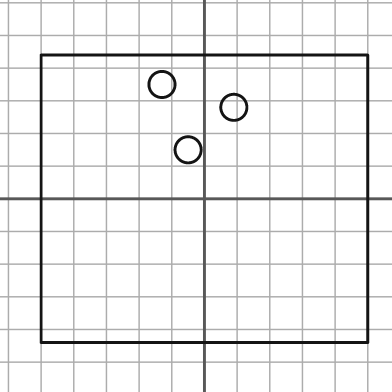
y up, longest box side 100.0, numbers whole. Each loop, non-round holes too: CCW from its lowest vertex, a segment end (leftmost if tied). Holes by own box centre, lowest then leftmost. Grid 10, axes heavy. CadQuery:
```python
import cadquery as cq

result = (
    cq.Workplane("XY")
    .moveTo(-50.0, -44.0)
    .lineTo(50.0, -44.0)
    .lineTo(50.0, 44.0)
    .lineTo(-50.0, 44.0)
    .close()
    .moveTo(-5.0, 15.0)
    .circle(4.0)
    .moveTo(9.0, 28.0)
    .circle(4.0)
    .moveTo(-13.0, 35.0)
    .circle(4.0)
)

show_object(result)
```